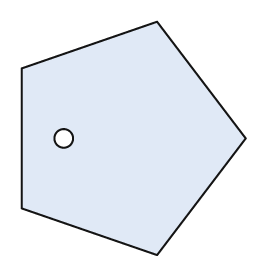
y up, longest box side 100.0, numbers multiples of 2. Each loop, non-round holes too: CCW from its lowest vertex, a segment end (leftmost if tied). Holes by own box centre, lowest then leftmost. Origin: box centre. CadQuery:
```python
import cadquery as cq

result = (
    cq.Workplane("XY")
    .moveTo(10.0, -50.0)
    .lineTo(48.0, 0.0)
    .lineTo(10.0, 50.0)
    .lineTo(-48.0, 30.0)
    .lineTo(-48.0, -30.0)
    .close()
    .moveTo(-30.0, 0.0)
    .circle(4.0)
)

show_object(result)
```